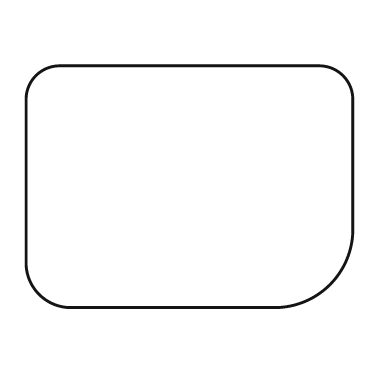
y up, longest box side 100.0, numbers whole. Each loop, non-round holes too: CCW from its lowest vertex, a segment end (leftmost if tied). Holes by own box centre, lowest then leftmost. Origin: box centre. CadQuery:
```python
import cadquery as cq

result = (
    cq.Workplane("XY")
    .moveTo(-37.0, -37.0)
    .lineTo(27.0, -37.0)
    .threePointArc((43.0, -30.0), (50.0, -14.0))
    .lineTo(50.0, 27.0)
    .threePointArc((47.0, 34.0), (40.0, 37.0))
    .lineTo(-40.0, 37.0)
    .threePointArc((-47.0, 34.0), (-50.0, 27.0))
    .lineTo(-50.0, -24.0)
    .threePointArc((-46.0, -33.0), (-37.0, -37.0))
    .close()
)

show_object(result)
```